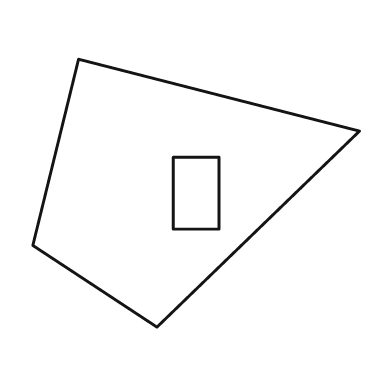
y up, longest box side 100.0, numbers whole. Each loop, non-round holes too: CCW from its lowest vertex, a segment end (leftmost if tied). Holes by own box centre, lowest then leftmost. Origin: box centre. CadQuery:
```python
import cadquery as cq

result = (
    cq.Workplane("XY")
    .moveTo(-12.0, -41.0)
    .lineTo(50.0, 19.0)
    .lineTo(-36.0, 41.0)
    .lineTo(-50.0, -16.0)
    .close()
    .moveTo(-7.0, -11.0)
    .lineTo(7.0, -11.0)
    .lineTo(7.0, 11.0)
    .lineTo(-7.0, 11.0)
    .close()
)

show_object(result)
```